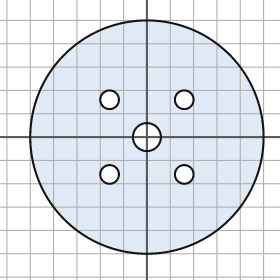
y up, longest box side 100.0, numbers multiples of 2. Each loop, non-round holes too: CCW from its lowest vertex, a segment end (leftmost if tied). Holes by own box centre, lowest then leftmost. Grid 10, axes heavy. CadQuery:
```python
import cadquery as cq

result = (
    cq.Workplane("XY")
    .moveTo(0.0, 0.0)
    .circle(50.0)
    .moveTo(-16.0, -16.0)
    .circle(4.0)
    .moveTo(16.0, -16.0)
    .circle(4.0)
    .moveTo(0.0, 0.0)
    .circle(6.0)
    .moveTo(-16.0, 16.0)
    .circle(4.0)
    .moveTo(16.0, 16.0)
    .circle(4.0)
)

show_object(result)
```